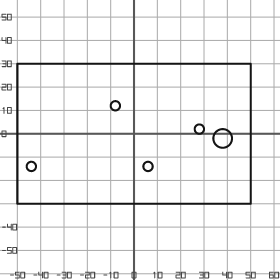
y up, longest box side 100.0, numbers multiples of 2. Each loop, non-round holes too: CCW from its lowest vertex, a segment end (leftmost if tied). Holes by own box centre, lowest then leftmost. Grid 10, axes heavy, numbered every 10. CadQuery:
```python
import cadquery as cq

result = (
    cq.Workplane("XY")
    .moveTo(-50.0, -30.0)
    .lineTo(50.0, -30.0)
    .lineTo(50.0, 30.0)
    .lineTo(-50.0, 30.0)
    .close()
    .moveTo(-44.0, -14.0)
    .circle(2.0)
    .moveTo(6.0, -14.0)
    .circle(2.0)
    .moveTo(38.0, -2.0)
    .circle(4.0)
    .moveTo(28.0, 2.0)
    .circle(2.0)
    .moveTo(-8.0, 12.0)
    .circle(2.0)
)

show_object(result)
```